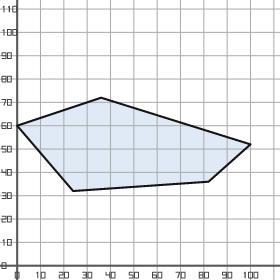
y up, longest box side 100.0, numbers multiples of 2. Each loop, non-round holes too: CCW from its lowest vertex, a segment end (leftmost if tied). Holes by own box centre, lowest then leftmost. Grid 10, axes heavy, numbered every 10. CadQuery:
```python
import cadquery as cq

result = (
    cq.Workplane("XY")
    .moveTo(24.0, 32.0)
    .lineTo(82.0, 36.0)
    .lineTo(100.0, 52.0)
    .lineTo(36.0, 72.0)
    .lineTo(0.0, 60.0)
    .close()
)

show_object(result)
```